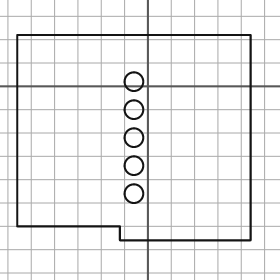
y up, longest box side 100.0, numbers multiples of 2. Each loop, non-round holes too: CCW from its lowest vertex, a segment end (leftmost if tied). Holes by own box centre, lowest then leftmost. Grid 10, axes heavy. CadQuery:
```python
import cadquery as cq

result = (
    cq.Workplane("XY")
    .moveTo(-12.0, -66.0)
    .lineTo(44.0, -66.0)
    .lineTo(44.0, 22.0)
    .lineTo(-56.0, 22.0)
    .lineTo(-56.0, -60.0)
    .lineTo(-12.0, -60.0)
    .close()
    .moveTo(-6.0, -46.0)
    .circle(4.0)
    .moveTo(-6.0, -34.0)
    .circle(4.0)
    .moveTo(-6.0, -22.0)
    .circle(4.0)
    .moveTo(-6.0, -10.0)
    .circle(4.0)
    .moveTo(-6.0, 2.0)
    .circle(4.0)
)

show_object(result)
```